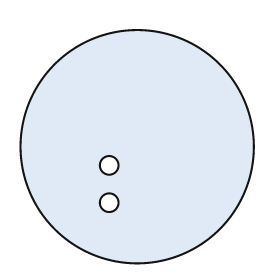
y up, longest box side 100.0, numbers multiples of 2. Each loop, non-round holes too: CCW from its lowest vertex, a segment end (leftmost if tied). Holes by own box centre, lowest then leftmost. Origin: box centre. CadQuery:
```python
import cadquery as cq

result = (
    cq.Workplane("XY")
    .moveTo(0.0, 0.0)
    .circle(50.0)
    .moveTo(-12.0, -24.0)
    .circle(4.0)
    .moveTo(-12.0, -8.0)
    .circle(4.0)
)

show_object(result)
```